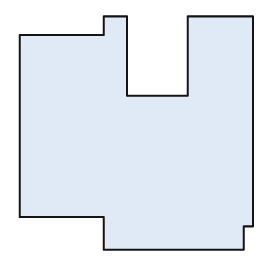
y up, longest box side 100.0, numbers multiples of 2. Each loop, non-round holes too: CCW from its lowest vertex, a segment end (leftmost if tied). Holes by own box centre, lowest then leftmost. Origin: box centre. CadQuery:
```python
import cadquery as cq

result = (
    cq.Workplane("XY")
    .moveTo(-14.0, -50.0)
    .lineTo(46.0, -50.0)
    .lineTo(46.0, -40.0)
    .lineTo(50.0, -40.0)
    .lineTo(50.0, 50.0)
    .lineTo(22.0, 50.0)
    .lineTo(22.0, 16.0)
    .lineTo(-4.0, 16.0)
    .lineTo(-4.0, 50.0)
    .lineTo(-14.0, 50.0)
    .lineTo(-14.0, 42.0)
    .lineTo(-50.0, 42.0)
    .lineTo(-50.0, -36.0)
    .lineTo(-14.0, -36.0)
    .close()
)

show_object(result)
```